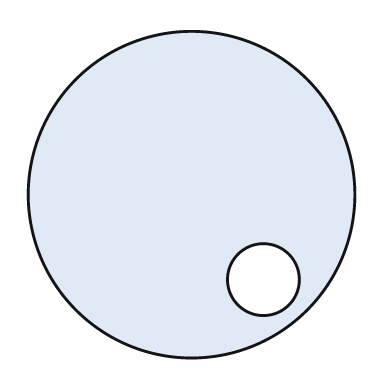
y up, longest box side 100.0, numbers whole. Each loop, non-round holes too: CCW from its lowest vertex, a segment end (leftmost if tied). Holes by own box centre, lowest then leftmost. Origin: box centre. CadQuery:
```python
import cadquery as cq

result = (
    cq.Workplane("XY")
    .moveTo(0.0, 0.0)
    .circle(50.0)
    .moveTo(22.0, -26.0)
    .circle(11.0)
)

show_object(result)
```